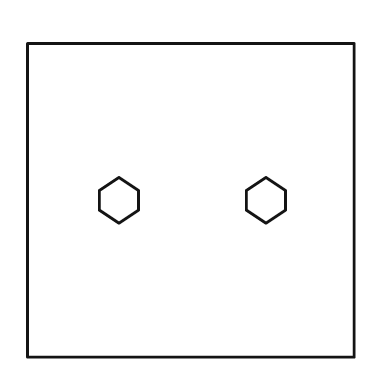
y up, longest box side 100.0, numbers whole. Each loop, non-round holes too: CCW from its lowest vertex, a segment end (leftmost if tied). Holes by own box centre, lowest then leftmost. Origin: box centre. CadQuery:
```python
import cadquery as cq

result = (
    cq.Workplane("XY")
    .moveTo(-50.0, -48.0)
    .lineTo(50.0, -48.0)
    .lineTo(50.0, 48.0)
    .lineTo(-50.0, 48.0)
    .close()
    .moveTo(-22.0, -7.0)
    .lineTo(-16.0, -3.0)
    .lineTo(-16.0, 3.0)
    .lineTo(-22.0, 7.0)
    .lineTo(-28.0, 3.0)
    .lineTo(-28.0, -3.0)
    .close()
    .moveTo(23.0, -7.0)
    .lineTo(29.0, -3.0)
    .lineTo(29.0, 3.0)
    .lineTo(23.0, 7.0)
    .lineTo(17.0, 3.0)
    .lineTo(17.0, -3.0)
    .close()
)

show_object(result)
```